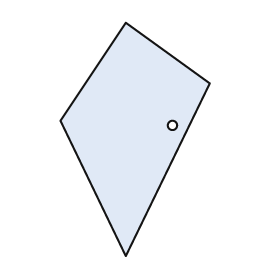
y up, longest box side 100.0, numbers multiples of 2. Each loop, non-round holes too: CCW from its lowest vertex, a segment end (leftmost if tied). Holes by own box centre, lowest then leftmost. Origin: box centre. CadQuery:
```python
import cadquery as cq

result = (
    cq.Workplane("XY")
    .moveTo(-4.0, -50.0)
    .lineTo(32.0, 24.0)
    .lineTo(-4.0, 50.0)
    .lineTo(-32.0, 8.0)
    .close()
    .moveTo(16.0, 6.0)
    .circle(2.0)
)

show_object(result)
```